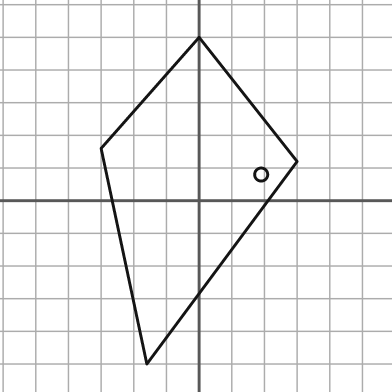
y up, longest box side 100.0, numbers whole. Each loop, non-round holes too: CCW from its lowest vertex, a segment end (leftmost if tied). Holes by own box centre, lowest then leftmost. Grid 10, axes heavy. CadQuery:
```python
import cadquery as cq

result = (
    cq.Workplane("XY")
    .moveTo(-16.0, -50.0)
    .lineTo(30.0, 12.0)
    .lineTo(0.0, 50.0)
    .lineTo(-30.0, 16.0)
    .close()
    .moveTo(19.0, 8.0)
    .circle(2.0)
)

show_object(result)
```